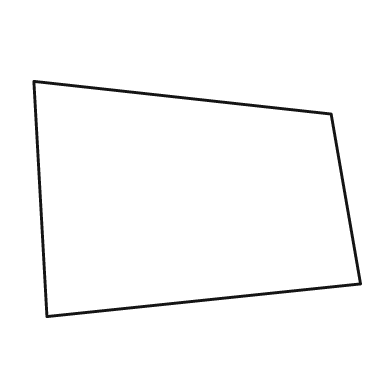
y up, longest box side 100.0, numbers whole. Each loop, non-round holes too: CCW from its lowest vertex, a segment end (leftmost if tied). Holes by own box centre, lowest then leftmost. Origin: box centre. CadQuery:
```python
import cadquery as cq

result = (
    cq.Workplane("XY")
    .moveTo(-46.0, -36.0)
    .lineTo(50.0, -26.0)
    .lineTo(41.0, 26.0)
    .lineTo(-50.0, 36.0)
    .close()
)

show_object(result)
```